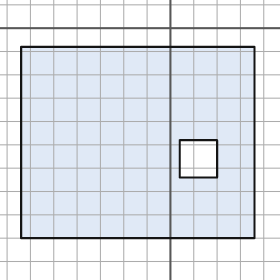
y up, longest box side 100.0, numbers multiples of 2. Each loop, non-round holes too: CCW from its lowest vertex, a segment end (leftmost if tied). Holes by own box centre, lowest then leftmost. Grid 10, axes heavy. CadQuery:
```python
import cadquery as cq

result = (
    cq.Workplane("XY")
    .moveTo(-64.0, -90.0)
    .lineTo(36.0, -90.0)
    .lineTo(36.0, -8.0)
    .lineTo(-64.0, -8.0)
    .close()
    .moveTo(4.0, -64.0)
    .lineTo(20.0, -64.0)
    .lineTo(20.0, -48.0)
    .lineTo(4.0, -48.0)
    .close()
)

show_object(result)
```